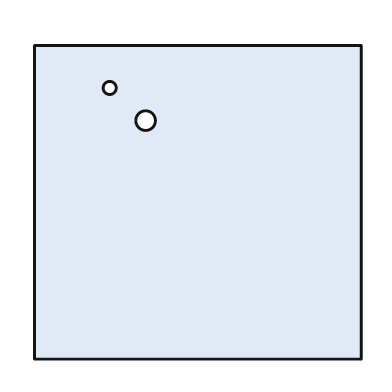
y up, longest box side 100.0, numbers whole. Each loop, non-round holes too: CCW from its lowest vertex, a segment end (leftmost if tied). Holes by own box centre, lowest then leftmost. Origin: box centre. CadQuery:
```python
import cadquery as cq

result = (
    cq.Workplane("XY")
    .moveTo(-50.0, -48.0)
    .lineTo(50.0, -48.0)
    .lineTo(50.0, 48.0)
    .lineTo(-50.0, 48.0)
    .close()
    .moveTo(-16.0, 25.0)
    .circle(3.0)
    .moveTo(-27.0, 35.0)
    .circle(2.0)
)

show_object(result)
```